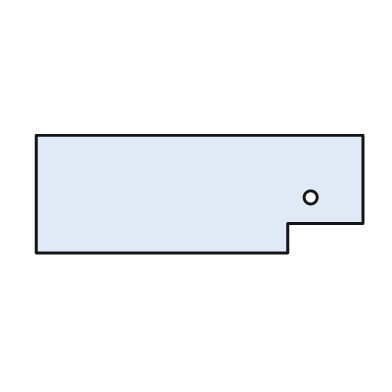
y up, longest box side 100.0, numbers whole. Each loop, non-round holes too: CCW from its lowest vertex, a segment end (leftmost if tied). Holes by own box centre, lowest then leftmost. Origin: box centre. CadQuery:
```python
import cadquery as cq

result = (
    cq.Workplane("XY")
    .moveTo(-50.0, -18.0)
    .lineTo(27.0, -18.0)
    .lineTo(27.0, -9.0)
    .lineTo(50.0, -9.0)
    .lineTo(50.0, 18.0)
    .lineTo(-50.0, 18.0)
    .close()
    .moveTo(34.0, -1.0)
    .circle(2.0)
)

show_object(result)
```